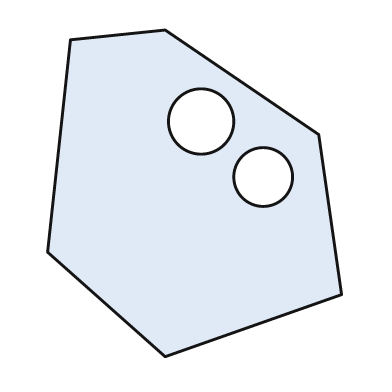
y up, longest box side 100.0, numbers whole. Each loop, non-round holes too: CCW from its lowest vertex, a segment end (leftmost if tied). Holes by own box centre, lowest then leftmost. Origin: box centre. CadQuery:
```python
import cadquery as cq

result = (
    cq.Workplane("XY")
    .moveTo(-9.0, -50.0)
    .lineTo(45.0, -31.0)
    .lineTo(38.0, 18.0)
    .lineTo(-9.0, 50.0)
    .lineTo(-38.0, 47.0)
    .lineTo(-45.0, -18.0)
    .close()
    .moveTo(21.0, 5.0)
    .circle(9.0)
    .moveTo(2.0, 22.0)
    .circle(10.0)
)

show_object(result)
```